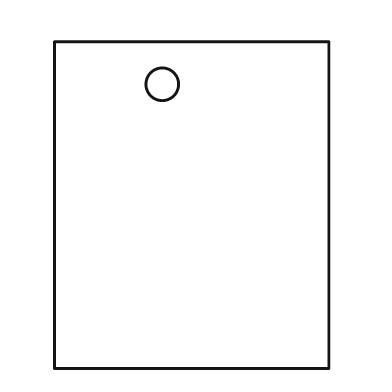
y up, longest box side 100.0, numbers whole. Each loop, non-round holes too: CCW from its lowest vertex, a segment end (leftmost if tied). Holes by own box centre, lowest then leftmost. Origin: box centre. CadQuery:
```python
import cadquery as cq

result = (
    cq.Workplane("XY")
    .moveTo(-42.0, -50.0)
    .lineTo(42.0, -50.0)
    .lineTo(42.0, 50.0)
    .lineTo(-42.0, 50.0)
    .close()
    .moveTo(-9.0, 37.0)
    .circle(5.0)
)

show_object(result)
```